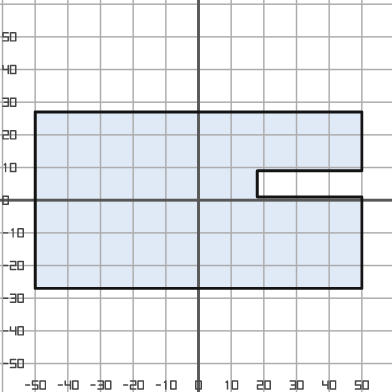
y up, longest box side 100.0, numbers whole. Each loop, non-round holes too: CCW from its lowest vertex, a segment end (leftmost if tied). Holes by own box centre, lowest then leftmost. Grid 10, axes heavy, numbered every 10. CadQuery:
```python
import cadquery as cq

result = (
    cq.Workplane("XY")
    .moveTo(-50.0, -27.0)
    .lineTo(50.0, -27.0)
    .lineTo(50.0, 1.0)
    .lineTo(18.0, 1.0)
    .lineTo(18.0, 9.0)
    .lineTo(50.0, 9.0)
    .lineTo(50.0, 27.0)
    .lineTo(-50.0, 27.0)
    .close()
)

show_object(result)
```